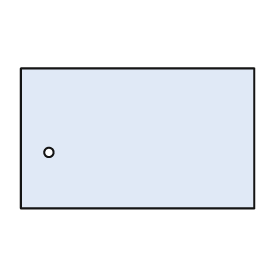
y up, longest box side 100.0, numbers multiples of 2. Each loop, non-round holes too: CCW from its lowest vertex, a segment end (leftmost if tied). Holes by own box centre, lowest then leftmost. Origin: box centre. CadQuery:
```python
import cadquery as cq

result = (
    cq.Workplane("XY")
    .moveTo(-50.0, -30.0)
    .lineTo(50.0, -30.0)
    .lineTo(50.0, 30.0)
    .lineTo(-50.0, 30.0)
    .close()
    .moveTo(-38.0, -6.0)
    .circle(2.0)
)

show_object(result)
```